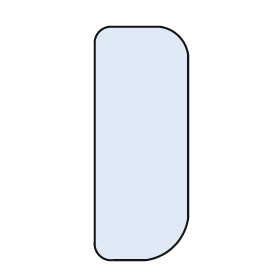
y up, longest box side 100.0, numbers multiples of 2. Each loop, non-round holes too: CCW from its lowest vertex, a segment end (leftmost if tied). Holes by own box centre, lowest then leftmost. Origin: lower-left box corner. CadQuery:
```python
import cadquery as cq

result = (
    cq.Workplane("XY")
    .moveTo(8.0, 0.0)
    .lineTo(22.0, 0.0)
    .threePointArc((34.0, 6.0), (40.0, 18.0))
    .lineTo(40.0, 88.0)
    .threePointArc((36.0, 96.0), (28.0, 100.0))
    .lineTo(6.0, 100.0)
    .threePointArc((2.0, 98.0), (0.0, 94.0))
    .lineTo(0.0, 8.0)
    .threePointArc((2.0, 2.0), (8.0, 0.0))
    .close()
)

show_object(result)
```